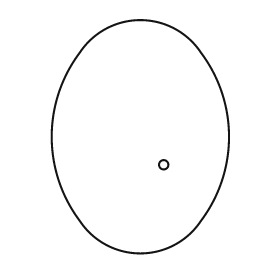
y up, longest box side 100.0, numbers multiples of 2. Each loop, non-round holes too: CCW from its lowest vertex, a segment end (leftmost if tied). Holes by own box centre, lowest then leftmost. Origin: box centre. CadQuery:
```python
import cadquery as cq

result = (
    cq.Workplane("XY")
    .moveTo(-26.0, -36.0)
    .threePointArc((0.0, -50.0), (26.0, -36.0))
    .threePointArc((38.0, 0.0), (26.0, 36.0))
    .threePointArc((0.0, 50.0), (-26.0, 36.0))
    .threePointArc((-38.0, 0.0), (-26.0, -36.0))
    .close()
    .moveTo(10.0, -12.0)
    .circle(2.0)
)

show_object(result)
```